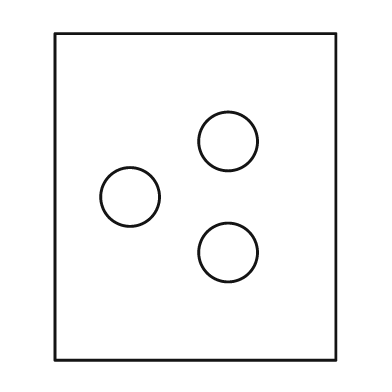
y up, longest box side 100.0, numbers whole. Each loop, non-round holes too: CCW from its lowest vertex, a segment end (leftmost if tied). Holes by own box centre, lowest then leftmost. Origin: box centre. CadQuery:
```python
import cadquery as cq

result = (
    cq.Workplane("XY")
    .moveTo(-43.0, -50.0)
    .lineTo(43.0, -50.0)
    .lineTo(43.0, 50.0)
    .lineTo(-43.0, 50.0)
    .close()
    .moveTo(10.0, -17.0)
    .circle(9.0)
    .moveTo(-20.0, 0.0)
    .circle(9.0)
    .moveTo(10.0, 17.0)
    .circle(9.0)
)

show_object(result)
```